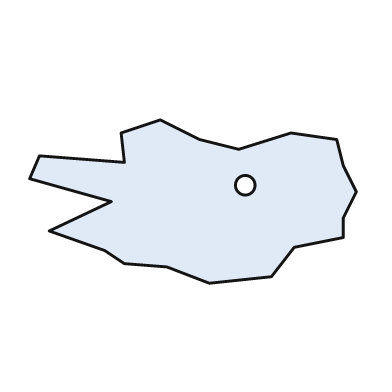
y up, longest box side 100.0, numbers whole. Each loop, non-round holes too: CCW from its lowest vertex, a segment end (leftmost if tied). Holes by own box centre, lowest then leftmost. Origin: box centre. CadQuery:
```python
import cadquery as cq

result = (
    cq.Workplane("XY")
    .moveTo(5.0, -25.0)
    .lineTo(24.0, -23.0)
    .lineTo(31.0, -14.0)
    .lineTo(46.0, -11.0)
    .lineTo(46.0, -5.0)
    .lineTo(50.0, 3.0)
    .lineTo(46.0, 11.0)
    .lineTo(44.0, 19.0)
    .lineTo(30.0, 21.0)
    .lineTo(14.0, 16.0)
    .lineTo(2.0, 19.0)
    .lineTo(-10.0, 25.0)
    .lineTo(-22.0, 21.0)
    .lineTo(-21.0, 12.0)
    .lineTo(-47.0, 14.0)
    .lineTo(-50.0, 7.0)
    .lineTo(-25.0, 0.0)
    .lineTo(-44.0, -9.0)
    .lineTo(-27.0, -15.0)
    .lineTo(-21.0, -19.0)
    .lineTo(-8.0, -20.0)
    .close()
    .moveTo(16.0, 5.0)
    .circle(3.0)
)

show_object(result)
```